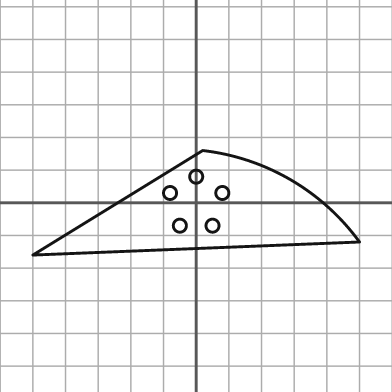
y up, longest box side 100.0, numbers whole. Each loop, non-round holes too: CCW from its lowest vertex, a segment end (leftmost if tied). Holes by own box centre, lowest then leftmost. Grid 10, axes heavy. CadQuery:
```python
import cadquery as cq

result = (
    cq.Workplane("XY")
    .moveTo(-50.0, -16.0)
    .lineTo(50.0, -12.0)
    .threePointArc((29.0, 7.0), (2.0, 16.0))
    .close()
    .moveTo(-5.0, -7.0)
    .circle(2.0)
    .moveTo(5.0, -7.0)
    .circle(2.0)
    .moveTo(-8.0, 3.0)
    .circle(2.0)
    .moveTo(8.0, 3.0)
    .circle(2.0)
    .moveTo(0.0, 8.0)
    .circle(2.0)
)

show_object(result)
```